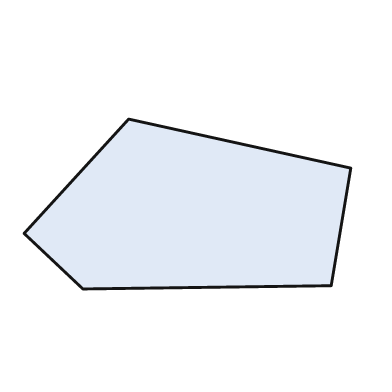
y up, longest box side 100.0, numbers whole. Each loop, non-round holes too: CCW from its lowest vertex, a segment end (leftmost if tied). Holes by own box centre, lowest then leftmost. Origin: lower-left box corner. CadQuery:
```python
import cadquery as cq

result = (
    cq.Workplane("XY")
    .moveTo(18.0, 0.0)
    .lineTo(94.0, 1.0)
    .lineTo(100.0, 37.0)
    .lineTo(32.0, 52.0)
    .lineTo(0.0, 17.0)
    .close()
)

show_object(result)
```